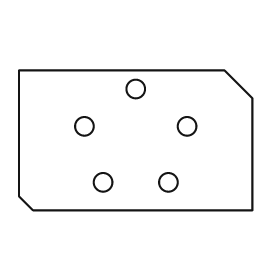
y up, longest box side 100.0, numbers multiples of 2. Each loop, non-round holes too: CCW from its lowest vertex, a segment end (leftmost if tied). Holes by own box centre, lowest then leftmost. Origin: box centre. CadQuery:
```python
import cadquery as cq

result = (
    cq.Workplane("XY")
    .moveTo(-44.0, -30.0)
    .lineTo(50.0, -30.0)
    .lineTo(50.0, 18.0)
    .lineTo(38.0, 30.0)
    .lineTo(-50.0, 30.0)
    .lineTo(-50.0, -24.0)
    .close()
    .moveTo(-14.0, -18.0)
    .circle(4.0)
    .moveTo(14.0, -18.0)
    .circle(4.0)
    .moveTo(-22.0, 6.0)
    .circle(4.0)
    .moveTo(22.0, 6.0)
    .circle(4.0)
    .moveTo(0.0, 22.0)
    .circle(4.0)
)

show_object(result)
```